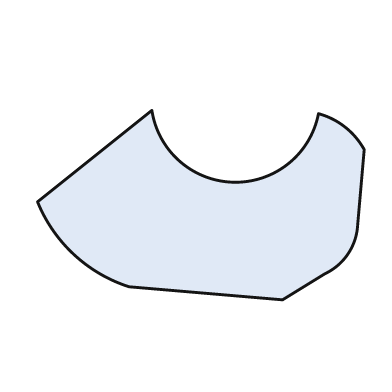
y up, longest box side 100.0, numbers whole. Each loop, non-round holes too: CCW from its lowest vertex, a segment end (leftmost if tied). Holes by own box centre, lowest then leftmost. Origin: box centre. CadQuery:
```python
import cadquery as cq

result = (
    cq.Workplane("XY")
    .moveTo(25.0, -29.0)
    .lineTo(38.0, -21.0)
    .threePointArc((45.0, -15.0), (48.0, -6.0))
    .lineTo(50.0, 17.0)
    .threePointArc((44.0, 24.0), (36.0, 28.0))
    .threePointArc((10.0, 7.0), (-15.0, 29.0))
    .lineTo(-50.0, 1.0)
    .threePointArc((-39.0, -15.0), (-22.0, -25.0))
    .close()
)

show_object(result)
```